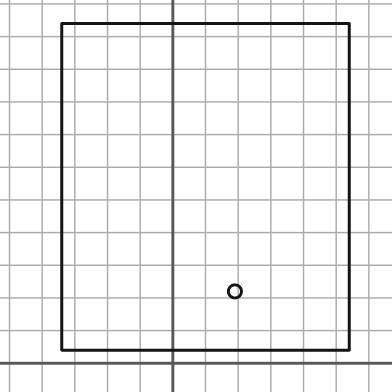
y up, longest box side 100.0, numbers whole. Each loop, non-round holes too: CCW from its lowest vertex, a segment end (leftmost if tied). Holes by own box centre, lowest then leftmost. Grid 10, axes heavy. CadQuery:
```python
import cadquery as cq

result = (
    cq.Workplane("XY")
    .moveTo(-34.0, 4.0)
    .lineTo(54.0, 4.0)
    .lineTo(54.0, 104.0)
    .lineTo(-34.0, 104.0)
    .close()
    .moveTo(19.0, 22.0)
    .circle(2.0)
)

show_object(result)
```